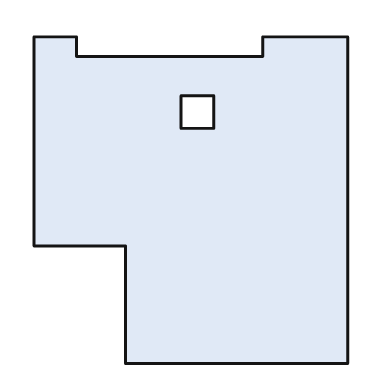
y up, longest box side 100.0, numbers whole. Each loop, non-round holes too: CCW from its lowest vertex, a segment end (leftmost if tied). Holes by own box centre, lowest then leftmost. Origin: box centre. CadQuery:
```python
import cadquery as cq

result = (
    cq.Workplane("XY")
    .moveTo(-20.0, -50.0)
    .lineTo(48.0, -50.0)
    .lineTo(48.0, 50.0)
    .lineTo(22.0, 50.0)
    .lineTo(22.0, 44.0)
    .lineTo(-35.0, 44.0)
    .lineTo(-35.0, 50.0)
    .lineTo(-48.0, 50.0)
    .lineTo(-48.0, -14.0)
    .lineTo(-20.0, -14.0)
    .close()
    .moveTo(-3.0, 22.0)
    .lineTo(7.0, 22.0)
    .lineTo(7.0, 32.0)
    .lineTo(-3.0, 32.0)
    .close()
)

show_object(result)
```